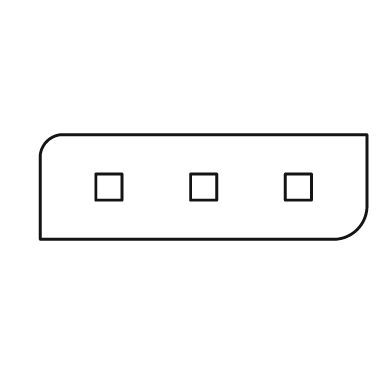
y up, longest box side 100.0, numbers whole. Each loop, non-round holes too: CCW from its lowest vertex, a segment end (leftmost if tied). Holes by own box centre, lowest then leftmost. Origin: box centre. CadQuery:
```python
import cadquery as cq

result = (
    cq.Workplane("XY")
    .moveTo(-50.0, -16.0)
    .lineTo(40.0, -16.0)
    .threePointArc((47.0, -13.0), (50.0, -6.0))
    .lineTo(50.0, 16.0)
    .lineTo(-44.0, 16.0)
    .threePointArc((-48.0, 14.0), (-50.0, 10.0))
    .close()
    .moveTo(-33.0, -4.0)
    .lineTo(-25.0, -4.0)
    .lineTo(-25.0, 4.0)
    .lineTo(-33.0, 4.0)
    .close()
    .moveTo(-4.0, -4.0)
    .lineTo(4.0, -4.0)
    .lineTo(4.0, 4.0)
    .lineTo(-4.0, 4.0)
    .close()
    .moveTo(25.0, -4.0)
    .lineTo(33.0, -4.0)
    .lineTo(33.0, 4.0)
    .lineTo(25.0, 4.0)
    .close()
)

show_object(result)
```